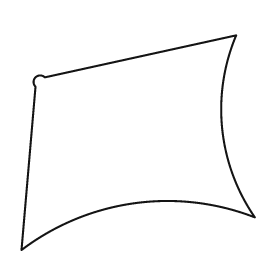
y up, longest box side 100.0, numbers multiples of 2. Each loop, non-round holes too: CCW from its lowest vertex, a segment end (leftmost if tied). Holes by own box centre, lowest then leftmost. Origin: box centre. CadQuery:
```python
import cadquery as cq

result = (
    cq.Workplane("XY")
    .moveTo(-50.0, -46.0)
    .threePointArc((-2.0, -26.0), (50.0, -32.0))
    .threePointArc((36.0, 6.0), (42.0, 46.0))
    .lineTo(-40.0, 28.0)
    .threePointArc((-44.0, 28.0), (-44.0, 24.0))
    .close()
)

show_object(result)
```